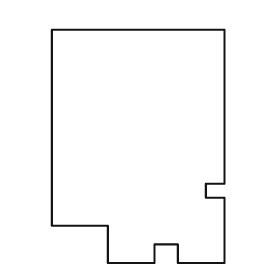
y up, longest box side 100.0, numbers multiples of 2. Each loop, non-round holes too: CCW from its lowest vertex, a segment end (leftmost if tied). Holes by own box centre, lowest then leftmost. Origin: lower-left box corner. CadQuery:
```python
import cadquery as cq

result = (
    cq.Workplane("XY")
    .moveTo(24.0, 0.0)
    .lineTo(44.0, 0.0)
    .lineTo(44.0, 8.0)
    .lineTo(54.0, 8.0)
    .lineTo(54.0, 0.0)
    .lineTo(74.0, 0.0)
    .lineTo(74.0, 28.0)
    .lineTo(66.0, 28.0)
    .lineTo(66.0, 34.0)
    .lineTo(74.0, 34.0)
    .lineTo(74.0, 100.0)
    .lineTo(0.0, 100.0)
    .lineTo(0.0, 16.0)
    .lineTo(24.0, 16.0)
    .close()
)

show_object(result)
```